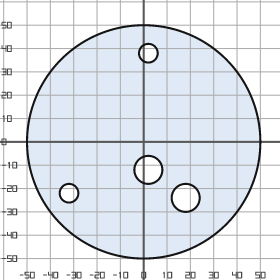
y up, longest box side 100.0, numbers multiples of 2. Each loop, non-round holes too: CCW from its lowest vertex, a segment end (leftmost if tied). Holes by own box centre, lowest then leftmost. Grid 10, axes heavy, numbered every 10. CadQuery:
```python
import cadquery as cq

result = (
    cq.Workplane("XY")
    .moveTo(0.0, 0.0)
    .circle(50.0)
    .moveTo(18.0, -24.0)
    .circle(6.0)
    .moveTo(-32.0, -22.0)
    .circle(4.0)
    .moveTo(2.0, -12.0)
    .circle(6.0)
    .moveTo(2.0, 38.0)
    .circle(4.0)
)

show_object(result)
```